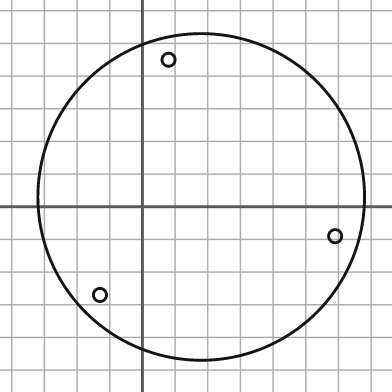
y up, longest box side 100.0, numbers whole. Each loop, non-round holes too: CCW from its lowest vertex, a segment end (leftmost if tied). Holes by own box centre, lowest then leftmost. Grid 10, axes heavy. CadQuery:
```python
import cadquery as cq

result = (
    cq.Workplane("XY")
    .moveTo(18.0, 3.0)
    .circle(50.0)
    .moveTo(-13.0, -27.0)
    .circle(2.0)
    .moveTo(59.0, -9.0)
    .circle(2.0)
    .moveTo(8.0, 45.0)
    .circle(2.0)
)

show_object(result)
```